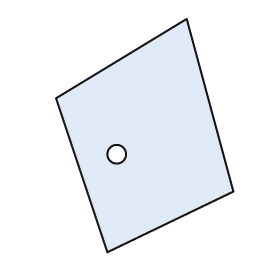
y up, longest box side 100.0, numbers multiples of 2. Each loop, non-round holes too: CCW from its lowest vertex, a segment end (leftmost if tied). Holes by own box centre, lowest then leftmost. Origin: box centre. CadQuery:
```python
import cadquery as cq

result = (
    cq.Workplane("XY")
    .moveTo(-16.0, -50.0)
    .lineTo(38.0, -24.0)
    .lineTo(18.0, 50.0)
    .lineTo(-38.0, 16.0)
    .close()
    .moveTo(-12.0, -8.0)
    .circle(4.0)
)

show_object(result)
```